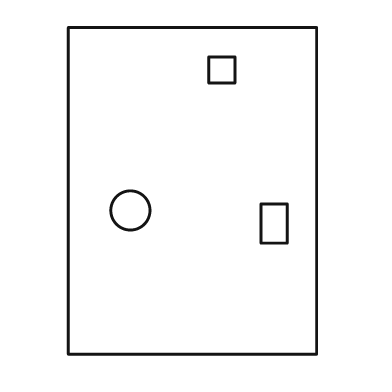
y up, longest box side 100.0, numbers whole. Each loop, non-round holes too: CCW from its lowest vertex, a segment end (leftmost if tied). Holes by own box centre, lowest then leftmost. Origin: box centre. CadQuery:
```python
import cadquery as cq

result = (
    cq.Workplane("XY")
    .moveTo(-38.0, -50.0)
    .lineTo(38.0, -50.0)
    .lineTo(38.0, 50.0)
    .lineTo(-38.0, 50.0)
    .close()
    .moveTo(21.0, -16.0)
    .lineTo(29.0, -16.0)
    .lineTo(29.0, -4.0)
    .lineTo(21.0, -4.0)
    .close()
    .moveTo(-19.0, -6.0)
    .circle(6.0)
    .moveTo(5.0, 33.0)
    .lineTo(13.0, 33.0)
    .lineTo(13.0, 41.0)
    .lineTo(5.0, 41.0)
    .close()
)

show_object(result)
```